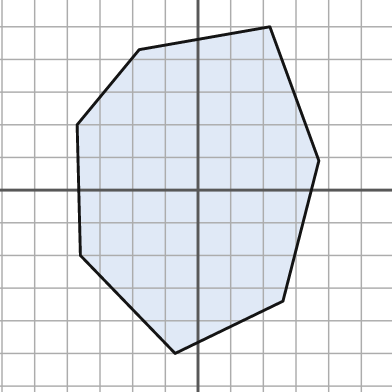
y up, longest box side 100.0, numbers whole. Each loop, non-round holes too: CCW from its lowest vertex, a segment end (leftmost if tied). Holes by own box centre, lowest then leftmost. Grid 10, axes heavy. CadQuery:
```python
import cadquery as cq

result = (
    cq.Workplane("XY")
    .moveTo(-7.0, -50.0)
    .lineTo(26.0, -34.0)
    .lineTo(37.0, 9.0)
    .lineTo(22.0, 50.0)
    .lineTo(-18.0, 43.0)
    .lineTo(-37.0, 20.0)
    .lineTo(-36.0, -20.0)
    .close()
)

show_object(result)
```